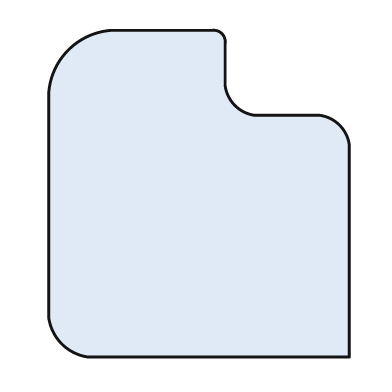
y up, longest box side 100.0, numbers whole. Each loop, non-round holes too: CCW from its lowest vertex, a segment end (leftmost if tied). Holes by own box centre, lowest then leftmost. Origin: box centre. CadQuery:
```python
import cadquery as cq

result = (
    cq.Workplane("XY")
    .moveTo(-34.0, -50.0)
    .lineTo(46.0, -50.0)
    .lineTo(46.0, 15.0)
    .threePointArc((43.0, 21.0), (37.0, 24.0))
    .lineTo(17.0, 24.0)
    .threePointArc((11.0, 27.0), (8.0, 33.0))
    .lineTo(8.0, 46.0)
    .threePointArc((7.0, 49.0), (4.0, 50.0))
    .lineTo(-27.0, 50.0)
    .threePointArc((-40.0, 44.0), (-46.0, 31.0))
    .lineTo(-46.0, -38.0)
    .threePointArc((-42.0, -46.0), (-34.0, -50.0))
    .close()
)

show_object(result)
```